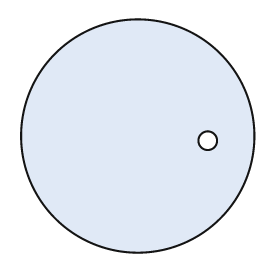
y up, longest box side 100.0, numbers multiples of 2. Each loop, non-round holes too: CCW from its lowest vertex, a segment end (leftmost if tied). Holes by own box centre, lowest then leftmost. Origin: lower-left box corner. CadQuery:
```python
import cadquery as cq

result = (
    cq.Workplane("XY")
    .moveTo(50.0, 50.0)
    .circle(50.0)
    .moveTo(80.0, 48.0)
    .circle(4.0)
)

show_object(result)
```